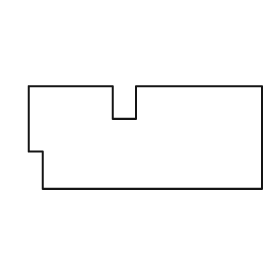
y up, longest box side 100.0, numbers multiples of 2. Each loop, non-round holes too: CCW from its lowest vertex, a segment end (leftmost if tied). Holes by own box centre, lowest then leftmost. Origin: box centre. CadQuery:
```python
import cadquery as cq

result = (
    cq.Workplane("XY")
    .moveTo(-44.0, -22.0)
    .lineTo(50.0, -22.0)
    .lineTo(50.0, 22.0)
    .lineTo(-4.0, 22.0)
    .lineTo(-4.0, 8.0)
    .lineTo(-14.0, 8.0)
    .lineTo(-14.0, 22.0)
    .lineTo(-50.0, 22.0)
    .lineTo(-50.0, -6.0)
    .lineTo(-44.0, -6.0)
    .close()
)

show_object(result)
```